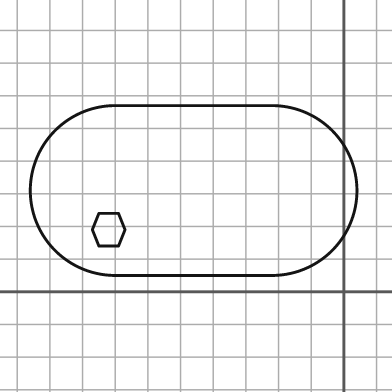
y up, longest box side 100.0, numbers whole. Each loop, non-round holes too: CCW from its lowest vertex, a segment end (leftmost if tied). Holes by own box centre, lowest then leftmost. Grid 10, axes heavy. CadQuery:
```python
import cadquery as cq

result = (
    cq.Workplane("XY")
    .moveTo(-70.0, 5.0)
    .lineTo(-22.0, 5.0)
    .threePointArc((4.0, 31.0), (-22.0, 57.0))
    .lineTo(-70.0, 57.0)
    .threePointArc((-96.0, 31.0), (-70.0, 5.0))
    .close()
    .moveTo(-75.0, 14.0)
    .lineTo(-69.0, 14.0)
    .lineTo(-67.0, 19.0)
    .lineTo(-69.0, 24.0)
    .lineTo(-75.0, 24.0)
    .lineTo(-77.0, 19.0)
    .close()
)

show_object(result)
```